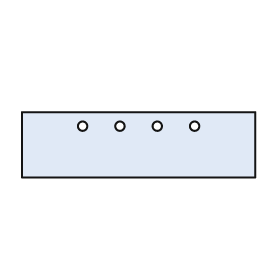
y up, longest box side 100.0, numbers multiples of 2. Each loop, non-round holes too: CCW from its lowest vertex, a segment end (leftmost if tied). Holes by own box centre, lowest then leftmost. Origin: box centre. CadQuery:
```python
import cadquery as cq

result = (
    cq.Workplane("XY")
    .moveTo(-50.0, -14.0)
    .lineTo(50.0, -14.0)
    .lineTo(50.0, 14.0)
    .lineTo(-50.0, 14.0)
    .close()
    .moveTo(-24.0, 8.0)
    .circle(2.0)
    .moveTo(-8.0, 8.0)
    .circle(2.0)
    .moveTo(8.0, 8.0)
    .circle(2.0)
    .moveTo(24.0, 8.0)
    .circle(2.0)
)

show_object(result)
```